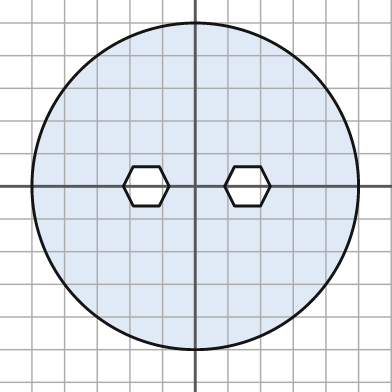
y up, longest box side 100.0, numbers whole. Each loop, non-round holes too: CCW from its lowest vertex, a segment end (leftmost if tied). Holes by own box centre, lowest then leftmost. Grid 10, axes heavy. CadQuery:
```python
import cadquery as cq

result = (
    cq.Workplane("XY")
    .moveTo(0.0, 0.0)
    .circle(50.0)
    .moveTo(-19.0, -6.0)
    .lineTo(-11.0, -6.0)
    .lineTo(-8.0, 0.0)
    .lineTo(-11.0, 6.0)
    .lineTo(-19.0, 6.0)
    .lineTo(-22.0, 0.0)
    .close()
    .moveTo(12.0, -6.0)
    .lineTo(20.0, -6.0)
    .lineTo(23.0, 0.0)
    .lineTo(20.0, 6.0)
    .lineTo(12.0, 6.0)
    .lineTo(9.0, 0.0)
    .close()
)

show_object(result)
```